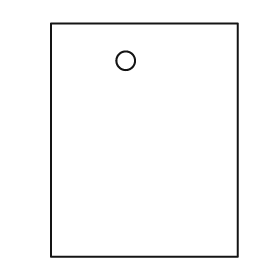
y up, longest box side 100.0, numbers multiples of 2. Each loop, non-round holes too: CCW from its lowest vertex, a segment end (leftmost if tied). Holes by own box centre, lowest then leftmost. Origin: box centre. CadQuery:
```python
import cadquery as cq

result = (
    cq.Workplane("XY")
    .moveTo(-40.0, -50.0)
    .lineTo(40.0, -50.0)
    .lineTo(40.0, 50.0)
    .lineTo(-40.0, 50.0)
    .close()
    .moveTo(-8.0, 34.0)
    .circle(4.0)
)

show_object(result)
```